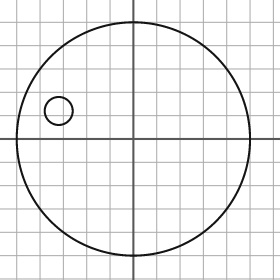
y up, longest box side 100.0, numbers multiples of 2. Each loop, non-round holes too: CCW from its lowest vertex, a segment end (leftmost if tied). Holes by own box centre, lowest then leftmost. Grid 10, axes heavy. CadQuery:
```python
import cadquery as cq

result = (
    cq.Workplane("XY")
    .moveTo(0.0, 0.0)
    .circle(50.0)
    .moveTo(-32.0, 12.0)
    .circle(6.0)
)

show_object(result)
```